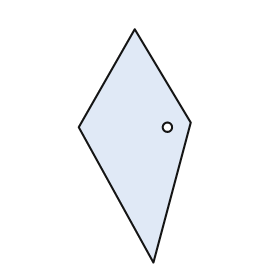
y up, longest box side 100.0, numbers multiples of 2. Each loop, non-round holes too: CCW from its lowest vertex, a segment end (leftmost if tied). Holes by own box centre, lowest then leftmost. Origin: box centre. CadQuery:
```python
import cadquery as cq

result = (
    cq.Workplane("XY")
    .moveTo(8.0, -50.0)
    .lineTo(24.0, 10.0)
    .lineTo(0.0, 50.0)
    .lineTo(-24.0, 8.0)
    .close()
    .moveTo(14.0, 8.0)
    .circle(2.0)
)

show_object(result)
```